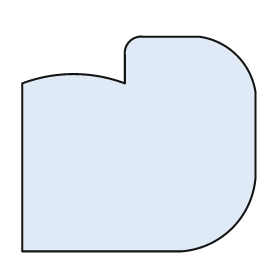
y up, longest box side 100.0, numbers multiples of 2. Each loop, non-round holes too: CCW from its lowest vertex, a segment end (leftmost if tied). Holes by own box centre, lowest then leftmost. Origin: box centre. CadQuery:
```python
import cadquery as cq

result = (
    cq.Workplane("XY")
    .moveTo(-50.0, -46.0)
    .lineTo(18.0, -46.0)
    .threePointArc((40.0, -36.0), (50.0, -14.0))
    .lineTo(50.0, 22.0)
    .threePointArc((42.0, 38.0), (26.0, 46.0))
    .lineTo(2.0, 46.0)
    .threePointArc((-4.0, 44.0), (-6.0, 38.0))
    .lineTo(-6.0, 26.0)
    .threePointArc((-28.0, 30.0), (-50.0, 26.0))
    .close()
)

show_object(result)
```